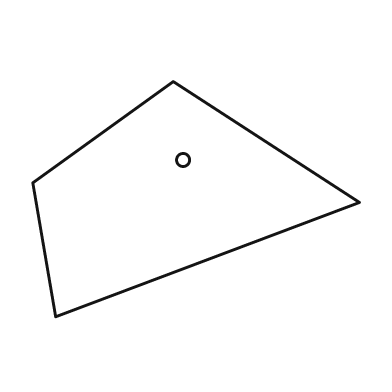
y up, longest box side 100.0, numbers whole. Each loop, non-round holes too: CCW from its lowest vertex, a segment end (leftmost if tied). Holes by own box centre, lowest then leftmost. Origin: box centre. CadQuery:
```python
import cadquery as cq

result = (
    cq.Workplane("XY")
    .moveTo(-43.0, -36.0)
    .lineTo(50.0, -1.0)
    .lineTo(-7.0, 36.0)
    .lineTo(-50.0, 5.0)
    .close()
    .moveTo(-4.0, 12.0)
    .circle(2.0)
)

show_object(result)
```